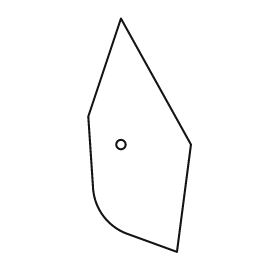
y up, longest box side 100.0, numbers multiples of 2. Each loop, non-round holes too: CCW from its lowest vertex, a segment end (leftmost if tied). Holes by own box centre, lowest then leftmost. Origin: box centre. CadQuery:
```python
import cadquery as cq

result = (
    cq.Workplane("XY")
    .moveTo(16.0, -50.0)
    .lineTo(22.0, -4.0)
    .lineTo(-8.0, 50.0)
    .lineTo(-22.0, 8.0)
    .lineTo(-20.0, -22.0)
    .threePointArc((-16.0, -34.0), (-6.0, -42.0))
    .close()
    .moveTo(-8.0, -4.0)
    .circle(2.0)
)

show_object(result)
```